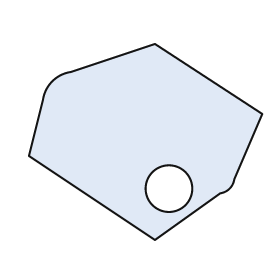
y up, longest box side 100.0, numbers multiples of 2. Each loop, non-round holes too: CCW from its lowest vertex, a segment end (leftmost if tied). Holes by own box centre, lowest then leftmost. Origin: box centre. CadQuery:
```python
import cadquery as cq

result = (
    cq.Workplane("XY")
    .moveTo(4.0, -42.0)
    .lineTo(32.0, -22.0)
    .threePointArc((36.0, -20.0), (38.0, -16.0))
    .lineTo(50.0, 12.0)
    .lineTo(4.0, 42.0)
    .lineTo(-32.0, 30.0)
    .threePointArc((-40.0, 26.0), (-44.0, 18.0))
    .lineTo(-50.0, -6.0)
    .close()
    .moveTo(10.0, -20.0)
    .circle(10.0)
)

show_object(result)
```